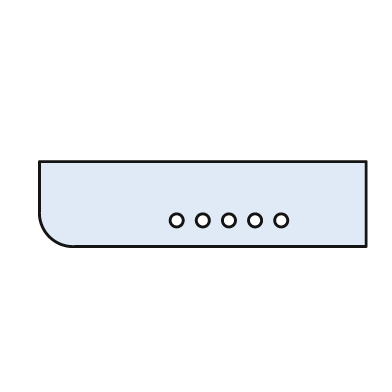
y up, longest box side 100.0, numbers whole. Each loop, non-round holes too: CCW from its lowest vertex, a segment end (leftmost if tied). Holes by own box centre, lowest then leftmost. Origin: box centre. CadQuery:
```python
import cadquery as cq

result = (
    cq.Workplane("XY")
    .moveTo(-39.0, -13.0)
    .lineTo(50.0, -13.0)
    .lineTo(50.0, 13.0)
    .lineTo(-50.0, 13.0)
    .lineTo(-50.0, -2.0)
    .threePointArc((-47.0, -10.0), (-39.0, -13.0))
    .close()
    .moveTo(-8.0, -5.0)
    .circle(2.0)
    .moveTo(0.0, -5.0)
    .circle(2.0)
    .moveTo(8.0, -5.0)
    .circle(2.0)
    .moveTo(16.0, -5.0)
    .circle(2.0)
    .moveTo(24.0, -5.0)
    .circle(2.0)
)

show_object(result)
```